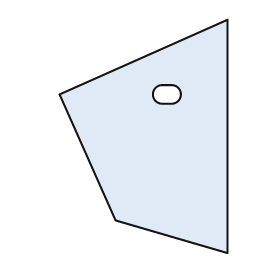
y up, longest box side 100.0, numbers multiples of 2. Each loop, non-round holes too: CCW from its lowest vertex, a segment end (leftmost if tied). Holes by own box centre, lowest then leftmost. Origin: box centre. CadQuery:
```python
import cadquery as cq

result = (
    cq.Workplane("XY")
    .moveTo(36.0, -50.0)
    .lineTo(36.0, 50.0)
    .lineTo(-36.0, 18.0)
    .lineTo(-12.0, -36.0)
    .close()
    .moveTo(8.0, 14.0)
    .lineTo(12.0, 14.0)
    .threePointArc((16.0, 18.0), (12.0, 22.0))
    .lineTo(8.0, 22.0)
    .threePointArc((4.0, 18.0), (8.0, 14.0))
    .close()
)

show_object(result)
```